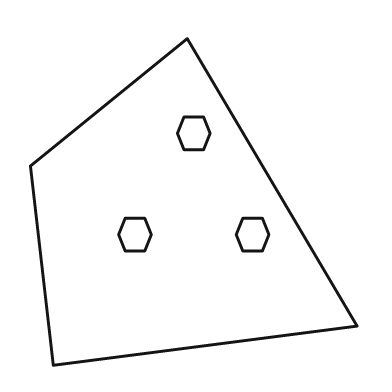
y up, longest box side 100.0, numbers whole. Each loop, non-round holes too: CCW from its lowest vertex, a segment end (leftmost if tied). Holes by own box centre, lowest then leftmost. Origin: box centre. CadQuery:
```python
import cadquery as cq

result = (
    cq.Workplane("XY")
    .moveTo(-43.0, -50.0)
    .lineTo(50.0, -38.0)
    .lineTo(-2.0, 50.0)
    .lineTo(-50.0, 11.0)
    .close()
    .moveTo(-21.0, -15.0)
    .lineTo(-15.0, -15.0)
    .lineTo(-13.0, -10.0)
    .lineTo(-15.0, -5.0)
    .lineTo(-21.0, -5.0)
    .lineTo(-23.0, -10.0)
    .close()
    .moveTo(15.0, -15.0)
    .lineTo(21.0, -15.0)
    .lineTo(23.0, -10.0)
    .lineTo(21.0, -5.0)
    .lineTo(15.0, -5.0)
    .lineTo(13.0, -10.0)
    .close()
    .moveTo(-3.0, 16.0)
    .lineTo(3.0, 16.0)
    .lineTo(5.0, 21.0)
    .lineTo(3.0, 26.0)
    .lineTo(-3.0, 26.0)
    .lineTo(-5.0, 21.0)
    .close()
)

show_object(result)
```